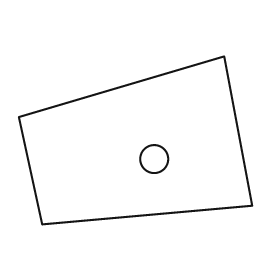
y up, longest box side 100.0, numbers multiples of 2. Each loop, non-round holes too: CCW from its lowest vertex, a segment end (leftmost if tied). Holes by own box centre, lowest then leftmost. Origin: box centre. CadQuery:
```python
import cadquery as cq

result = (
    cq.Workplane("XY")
    .moveTo(-40.0, -36.0)
    .lineTo(50.0, -28.0)
    .lineTo(38.0, 36.0)
    .lineTo(-50.0, 10.0)
    .close()
    .moveTo(8.0, -8.0)
    .circle(6.0)
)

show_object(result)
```